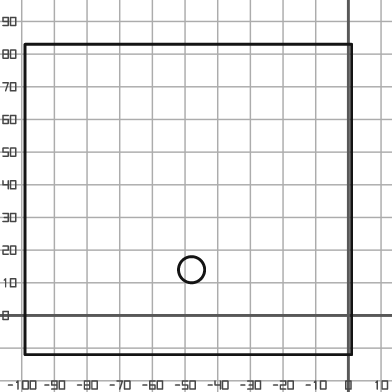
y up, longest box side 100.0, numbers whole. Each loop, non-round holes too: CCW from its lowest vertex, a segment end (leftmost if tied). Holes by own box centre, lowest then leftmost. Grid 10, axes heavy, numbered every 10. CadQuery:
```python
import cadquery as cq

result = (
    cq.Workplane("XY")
    .moveTo(-99.0, -12.0)
    .lineTo(1.0, -12.0)
    .lineTo(1.0, 83.0)
    .lineTo(-99.0, 83.0)
    .close()
    .moveTo(-48.0, 14.0)
    .circle(4.0)
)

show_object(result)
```